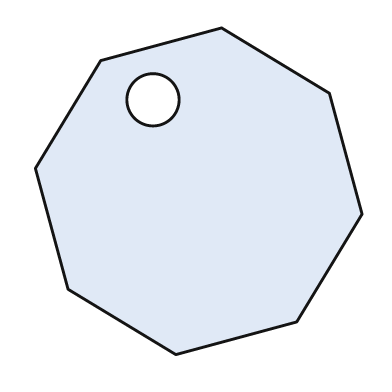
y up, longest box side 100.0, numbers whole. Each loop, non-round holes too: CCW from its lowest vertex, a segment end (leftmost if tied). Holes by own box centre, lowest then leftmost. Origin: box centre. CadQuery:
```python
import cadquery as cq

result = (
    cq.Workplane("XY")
    .moveTo(-7.0, -50.0)
    .lineTo(30.0, -40.0)
    .lineTo(50.0, -7.0)
    .lineTo(40.0, 30.0)
    .lineTo(7.0, 50.0)
    .lineTo(-30.0, 40.0)
    .lineTo(-50.0, 7.0)
    .lineTo(-40.0, -30.0)
    .close()
    .moveTo(-14.0, 28.0)
    .circle(8.0)
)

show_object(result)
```